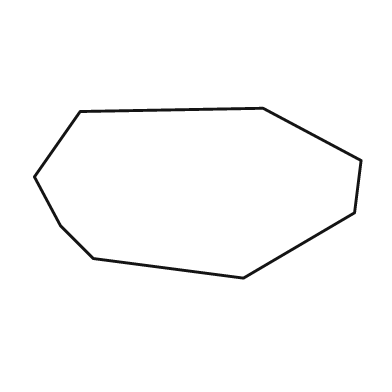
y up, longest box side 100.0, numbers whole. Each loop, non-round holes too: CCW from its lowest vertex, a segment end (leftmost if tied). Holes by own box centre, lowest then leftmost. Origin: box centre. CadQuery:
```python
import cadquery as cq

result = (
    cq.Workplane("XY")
    .moveTo(14.0, -26.0)
    .lineTo(48.0, -6.0)
    .lineTo(50.0, 10.0)
    .lineTo(20.0, 26.0)
    .lineTo(-36.0, 25.0)
    .lineTo(-50.0, 5.0)
    .lineTo(-42.0, -10.0)
    .lineTo(-32.0, -20.0)
    .close()
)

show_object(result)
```